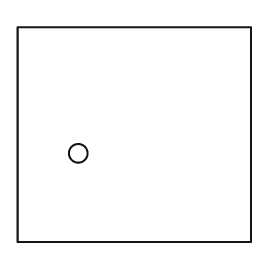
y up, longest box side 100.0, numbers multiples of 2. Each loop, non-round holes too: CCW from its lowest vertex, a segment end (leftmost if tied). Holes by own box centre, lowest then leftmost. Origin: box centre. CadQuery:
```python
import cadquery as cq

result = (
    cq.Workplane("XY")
    .moveTo(-50.0, -46.0)
    .lineTo(50.0, -46.0)
    .lineTo(50.0, 46.0)
    .lineTo(-50.0, 46.0)
    .close()
    .moveTo(-24.0, -8.0)
    .circle(4.0)
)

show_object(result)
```